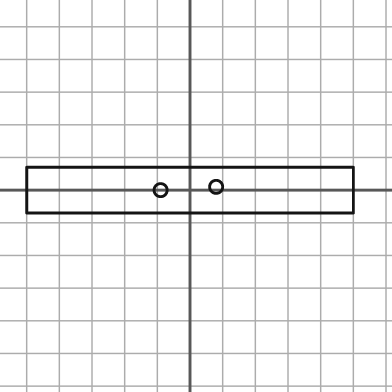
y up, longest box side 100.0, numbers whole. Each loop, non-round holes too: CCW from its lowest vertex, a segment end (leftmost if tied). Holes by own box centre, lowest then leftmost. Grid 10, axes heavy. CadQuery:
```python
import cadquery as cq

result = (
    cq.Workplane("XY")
    .moveTo(-50.0, -7.0)
    .lineTo(50.0, -7.0)
    .lineTo(50.0, 7.0)
    .lineTo(-50.0, 7.0)
    .close()
    .moveTo(-9.0, 0.0)
    .circle(2.0)
    .moveTo(8.0, 1.0)
    .circle(2.0)
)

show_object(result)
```